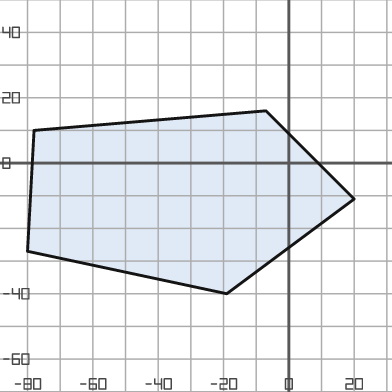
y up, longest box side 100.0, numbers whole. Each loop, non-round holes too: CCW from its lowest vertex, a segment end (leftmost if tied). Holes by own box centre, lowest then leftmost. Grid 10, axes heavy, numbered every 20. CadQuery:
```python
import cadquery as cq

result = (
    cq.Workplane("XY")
    .moveTo(-19.0, -40.0)
    .lineTo(20.0, -11.0)
    .lineTo(-7.0, 16.0)
    .lineTo(-78.0, 10.0)
    .lineTo(-80.0, -27.0)
    .close()
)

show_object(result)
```